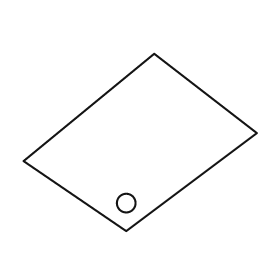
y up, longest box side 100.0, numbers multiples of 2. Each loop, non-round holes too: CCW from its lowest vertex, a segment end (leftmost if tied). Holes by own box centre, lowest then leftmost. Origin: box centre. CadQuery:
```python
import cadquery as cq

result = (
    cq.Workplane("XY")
    .moveTo(-6.0, -38.0)
    .lineTo(50.0, 4.0)
    .lineTo(6.0, 38.0)
    .lineTo(-50.0, -8.0)
    .close()
    .moveTo(-6.0, -26.0)
    .circle(4.0)
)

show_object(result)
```